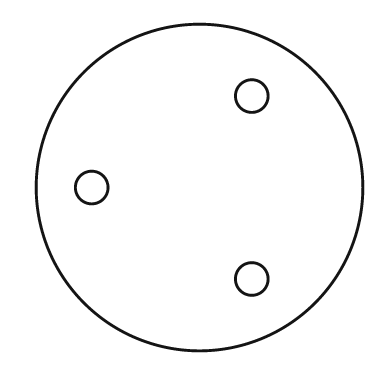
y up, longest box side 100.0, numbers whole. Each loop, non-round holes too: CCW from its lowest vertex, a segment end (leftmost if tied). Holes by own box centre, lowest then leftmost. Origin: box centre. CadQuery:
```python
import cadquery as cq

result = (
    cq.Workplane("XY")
    .moveTo(0.0, 0.0)
    .circle(50.0)
    .moveTo(16.0, -28.0)
    .circle(5.0)
    .moveTo(-33.0, 0.0)
    .circle(5.0)
    .moveTo(16.0, 28.0)
    .circle(5.0)
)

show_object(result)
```